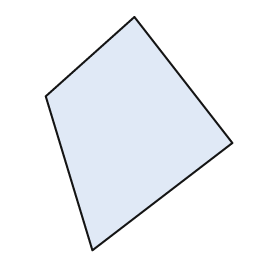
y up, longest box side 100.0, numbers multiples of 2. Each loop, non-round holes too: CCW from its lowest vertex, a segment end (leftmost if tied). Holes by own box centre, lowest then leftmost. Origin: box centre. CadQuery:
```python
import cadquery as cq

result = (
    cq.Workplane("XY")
    .moveTo(-20.0, -50.0)
    .lineTo(40.0, -4.0)
    .lineTo(-2.0, 50.0)
    .lineTo(-40.0, 16.0)
    .close()
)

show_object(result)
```